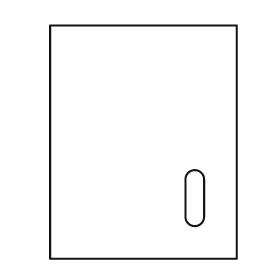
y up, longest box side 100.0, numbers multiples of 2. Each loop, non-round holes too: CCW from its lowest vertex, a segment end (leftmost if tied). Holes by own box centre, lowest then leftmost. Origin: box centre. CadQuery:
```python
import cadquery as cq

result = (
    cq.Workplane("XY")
    .moveTo(-40.0, -50.0)
    .lineTo(40.0, -50.0)
    .lineTo(40.0, 50.0)
    .lineTo(-40.0, 50.0)
    .close()
    .moveTo(18.0, -32.0)
    .threePointArc((22.0, -36.0), (26.0, -32.0))
    .lineTo(26.0, -16.0)
    .threePointArc((22.0, -12.0), (18.0, -16.0))
    .close()
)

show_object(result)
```